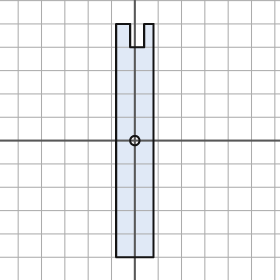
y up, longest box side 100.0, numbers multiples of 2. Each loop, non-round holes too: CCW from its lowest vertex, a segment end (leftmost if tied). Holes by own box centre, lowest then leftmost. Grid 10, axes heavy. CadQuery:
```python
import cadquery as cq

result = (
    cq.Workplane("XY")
    .moveTo(-8.0, -50.0)
    .lineTo(8.0, -50.0)
    .lineTo(8.0, 50.0)
    .lineTo(4.0, 50.0)
    .lineTo(4.0, 40.0)
    .lineTo(-2.0, 40.0)
    .lineTo(-2.0, 50.0)
    .lineTo(-8.0, 50.0)
    .close()
    .moveTo(0.0, 0.0)
    .circle(2.0)
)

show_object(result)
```